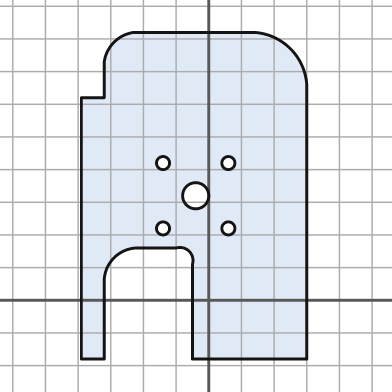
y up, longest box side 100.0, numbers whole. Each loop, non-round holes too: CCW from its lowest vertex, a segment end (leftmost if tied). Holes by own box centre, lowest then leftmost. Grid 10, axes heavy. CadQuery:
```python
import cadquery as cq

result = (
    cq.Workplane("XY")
    .moveTo(-39.0, -18.0)
    .lineTo(-32.0, -18.0)
    .lineTo(-32.0, 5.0)
    .threePointArc((-29.0, 13.0), (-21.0, 16.0))
    .lineTo(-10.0, 16.0)
    .threePointArc((-6.0, 15.0), (-5.0, 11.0))
    .lineTo(-5.0, -18.0)
    .lineTo(30.0, -18.0)
    .lineTo(30.0, 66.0)
    .threePointArc((25.0, 77.0), (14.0, 82.0))
    .lineTo(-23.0, 82.0)
    .threePointArc((-29.0, 79.0), (-32.0, 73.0))
    .lineTo(-32.0, 62.0)
    .lineTo(-39.0, 62.0)
    .close()
    .moveTo(-14.0, 22.0)
    .circle(2.0)
    .moveTo(6.0, 22.0)
    .circle(2.0)
    .moveTo(-4.0, 32.0)
    .circle(4.0)
    .moveTo(-14.0, 42.0)
    .circle(2.0)
    .moveTo(6.0, 42.0)
    .circle(2.0)
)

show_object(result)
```